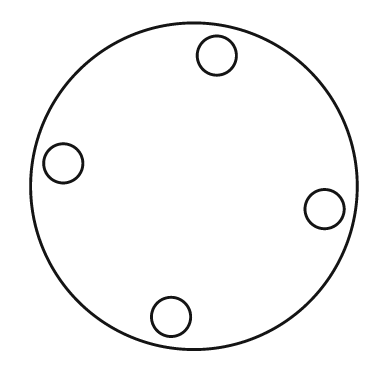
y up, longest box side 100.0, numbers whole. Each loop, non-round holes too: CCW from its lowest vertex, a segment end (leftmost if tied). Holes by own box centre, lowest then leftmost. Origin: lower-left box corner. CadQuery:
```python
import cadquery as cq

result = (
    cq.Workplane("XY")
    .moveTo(50.0, 50.0)
    .circle(50.0)
    .moveTo(43.0, 10.0)
    .circle(6.0)
    .moveTo(90.0, 43.0)
    .circle(6.0)
    .moveTo(10.0, 57.0)
    .circle(6.0)
    .moveTo(57.0, 90.0)
    .circle(6.0)
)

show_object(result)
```